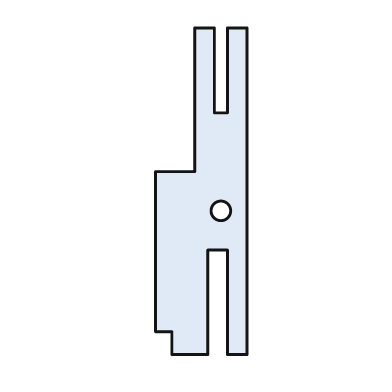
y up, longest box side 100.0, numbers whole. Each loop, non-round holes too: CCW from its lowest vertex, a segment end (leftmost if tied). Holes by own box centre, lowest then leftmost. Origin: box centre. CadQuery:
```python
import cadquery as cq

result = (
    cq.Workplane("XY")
    .moveTo(-9.0, -50.0)
    .lineTo(2.0, -50.0)
    .lineTo(2.0, -18.0)
    .lineTo(8.0, -18.0)
    .lineTo(8.0, -50.0)
    .lineTo(14.0, -50.0)
    .lineTo(14.0, 50.0)
    .lineTo(8.0, 50.0)
    .lineTo(8.0, 24.0)
    .lineTo(4.0, 24.0)
    .lineTo(4.0, 50.0)
    .lineTo(-2.0, 50.0)
    .lineTo(-2.0, 6.0)
    .lineTo(-14.0, 6.0)
    .lineTo(-14.0, -43.0)
    .lineTo(-9.0, -43.0)
    .close()
    .moveTo(6.0, -6.0)
    .circle(3.0)
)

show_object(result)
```